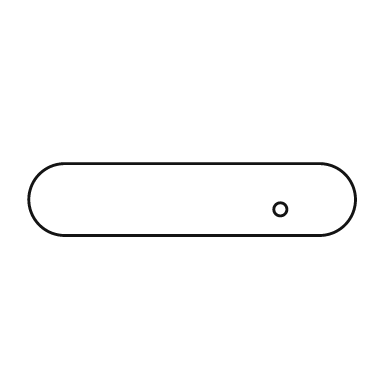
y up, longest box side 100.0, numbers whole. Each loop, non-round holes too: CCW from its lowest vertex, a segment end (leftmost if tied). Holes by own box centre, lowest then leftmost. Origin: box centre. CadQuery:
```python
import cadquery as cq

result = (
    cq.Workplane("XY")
    .moveTo(-39.0, -11.0)
    .lineTo(39.0, -11.0)
    .threePointArc((50.0, 0.0), (39.0, 11.0))
    .lineTo(-39.0, 11.0)
    .threePointArc((-50.0, 0.0), (-39.0, -11.0))
    .close()
    .moveTo(27.0, -3.0)
    .circle(2.0)
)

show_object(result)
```